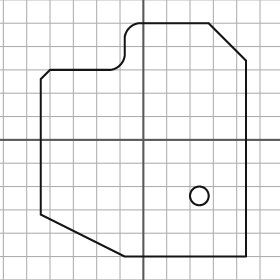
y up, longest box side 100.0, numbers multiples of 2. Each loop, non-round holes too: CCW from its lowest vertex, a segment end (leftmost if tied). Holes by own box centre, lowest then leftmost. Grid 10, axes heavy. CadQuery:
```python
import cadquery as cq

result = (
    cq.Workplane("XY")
    .moveTo(-8.0, -50.0)
    .lineTo(44.0, -50.0)
    .lineTo(44.0, 34.0)
    .lineTo(28.0, 50.0)
    .lineTo(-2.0, 50.0)
    .threePointArc((-6.0, 48.0), (-8.0, 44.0))
    .lineTo(-8.0, 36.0)
    .threePointArc((-10.0, 32.0), (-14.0, 30.0))
    .lineTo(-40.0, 30.0)
    .lineTo(-44.0, 26.0)
    .lineTo(-44.0, -32.0)
    .close()
    .moveTo(24.0, -24.0)
    .circle(4.0)
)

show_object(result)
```